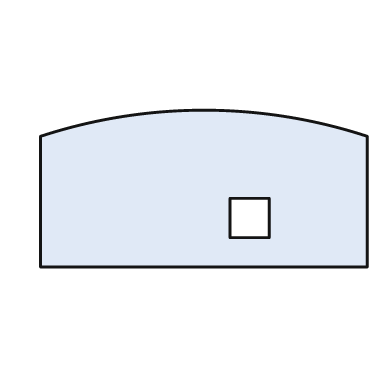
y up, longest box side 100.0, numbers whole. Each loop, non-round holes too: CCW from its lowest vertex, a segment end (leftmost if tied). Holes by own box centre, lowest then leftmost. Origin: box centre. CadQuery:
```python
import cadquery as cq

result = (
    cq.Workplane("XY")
    .moveTo(-50.0, -24.0)
    .lineTo(50.0, -24.0)
    .lineTo(50.0, 16.0)
    .threePointArc((0.0, 24.0), (-50.0, 16.0))
    .close()
    .moveTo(8.0, -15.0)
    .lineTo(20.0, -15.0)
    .lineTo(20.0, -3.0)
    .lineTo(8.0, -3.0)
    .close()
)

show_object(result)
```